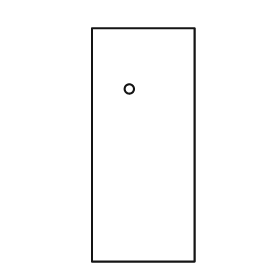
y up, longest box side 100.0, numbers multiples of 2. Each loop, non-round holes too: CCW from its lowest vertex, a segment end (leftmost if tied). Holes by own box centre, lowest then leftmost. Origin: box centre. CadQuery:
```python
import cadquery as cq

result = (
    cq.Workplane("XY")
    .moveTo(-22.0, -50.0)
    .lineTo(22.0, -50.0)
    .lineTo(22.0, 50.0)
    .lineTo(-22.0, 50.0)
    .close()
    .moveTo(-6.0, 24.0)
    .circle(2.0)
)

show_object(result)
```